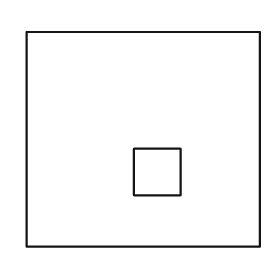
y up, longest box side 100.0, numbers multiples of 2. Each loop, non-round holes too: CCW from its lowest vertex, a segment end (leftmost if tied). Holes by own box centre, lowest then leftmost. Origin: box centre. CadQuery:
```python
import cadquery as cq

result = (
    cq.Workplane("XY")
    .moveTo(-50.0, -46.0)
    .lineTo(50.0, -46.0)
    .lineTo(50.0, 46.0)
    .lineTo(-50.0, 46.0)
    .close()
    .moveTo(-4.0, -24.0)
    .lineTo(16.0, -24.0)
    .lineTo(16.0, -4.0)
    .lineTo(-4.0, -4.0)
    .close()
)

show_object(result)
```